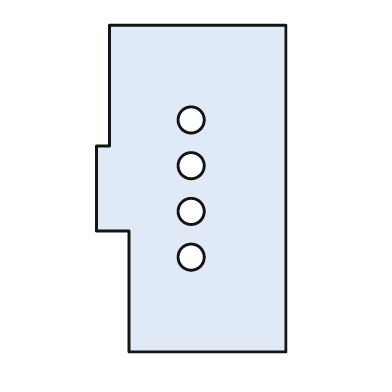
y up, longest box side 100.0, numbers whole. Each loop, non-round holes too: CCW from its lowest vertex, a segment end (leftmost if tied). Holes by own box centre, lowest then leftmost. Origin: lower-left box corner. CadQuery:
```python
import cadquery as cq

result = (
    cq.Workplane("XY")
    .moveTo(10.0, 0.0)
    .lineTo(58.0, 0.0)
    .lineTo(58.0, 100.0)
    .lineTo(4.0, 100.0)
    .lineTo(4.0, 63.0)
    .lineTo(0.0, 63.0)
    .lineTo(0.0, 37.0)
    .lineTo(10.0, 37.0)
    .close()
    .moveTo(29.0, 29.0)
    .circle(4.0)
    .moveTo(29.0, 43.0)
    .circle(4.0)
    .moveTo(29.0, 57.0)
    .circle(4.0)
    .moveTo(29.0, 71.0)
    .circle(4.0)
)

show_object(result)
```